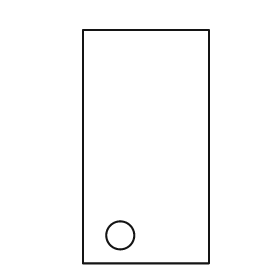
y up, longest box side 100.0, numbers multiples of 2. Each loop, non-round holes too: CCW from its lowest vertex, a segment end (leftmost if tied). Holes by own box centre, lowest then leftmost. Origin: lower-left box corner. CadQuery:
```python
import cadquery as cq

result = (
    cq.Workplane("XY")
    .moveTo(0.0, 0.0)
    .lineTo(54.0, 0.0)
    .lineTo(54.0, 100.0)
    .lineTo(0.0, 100.0)
    .close()
    .moveTo(16.0, 12.0)
    .circle(6.0)
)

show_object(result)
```